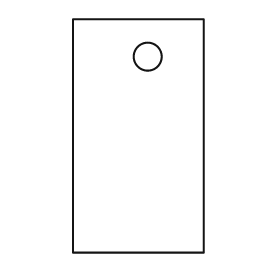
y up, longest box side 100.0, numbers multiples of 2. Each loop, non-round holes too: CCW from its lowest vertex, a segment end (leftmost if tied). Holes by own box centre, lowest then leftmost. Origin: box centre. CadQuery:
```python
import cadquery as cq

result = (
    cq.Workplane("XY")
    .moveTo(-28.0, -50.0)
    .lineTo(28.0, -50.0)
    .lineTo(28.0, 50.0)
    .lineTo(-28.0, 50.0)
    .close()
    .moveTo(4.0, 34.0)
    .circle(6.0)
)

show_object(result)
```